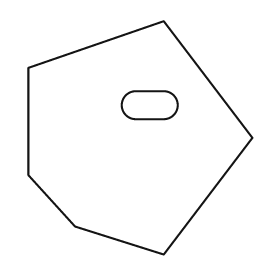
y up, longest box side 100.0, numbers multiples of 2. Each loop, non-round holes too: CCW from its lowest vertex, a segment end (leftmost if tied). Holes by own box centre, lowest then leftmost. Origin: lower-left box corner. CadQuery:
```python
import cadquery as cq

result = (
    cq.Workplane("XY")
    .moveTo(58.0, 0.0)
    .lineTo(96.0, 50.0)
    .lineTo(58.0, 100.0)
    .lineTo(0.0, 80.0)
    .lineTo(0.0, 34.0)
    .lineTo(20.0, 12.0)
    .close()
    .moveTo(46.0, 58.0)
    .lineTo(58.0, 58.0)
    .threePointArc((64.0, 64.0), (58.0, 70.0))
    .lineTo(46.0, 70.0)
    .threePointArc((40.0, 64.0), (46.0, 58.0))
    .close()
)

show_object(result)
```